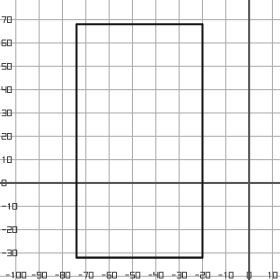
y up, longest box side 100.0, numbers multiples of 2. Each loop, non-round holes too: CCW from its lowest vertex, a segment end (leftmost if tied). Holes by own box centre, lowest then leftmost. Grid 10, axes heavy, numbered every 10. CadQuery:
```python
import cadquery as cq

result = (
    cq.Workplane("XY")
    .moveTo(-74.0, -32.0)
    .lineTo(-20.0, -32.0)
    .lineTo(-20.0, 68.0)
    .lineTo(-74.0, 68.0)
    .close()
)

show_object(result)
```